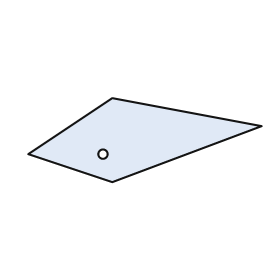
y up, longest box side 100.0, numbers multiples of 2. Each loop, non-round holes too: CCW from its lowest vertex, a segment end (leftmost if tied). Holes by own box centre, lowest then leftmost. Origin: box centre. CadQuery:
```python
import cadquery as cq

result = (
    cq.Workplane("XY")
    .moveTo(-14.0, -18.0)
    .lineTo(50.0, 6.0)
    .lineTo(-14.0, 18.0)
    .lineTo(-50.0, -6.0)
    .close()
    .moveTo(-18.0, -6.0)
    .circle(2.0)
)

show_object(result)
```